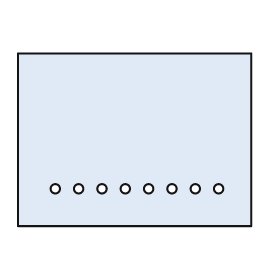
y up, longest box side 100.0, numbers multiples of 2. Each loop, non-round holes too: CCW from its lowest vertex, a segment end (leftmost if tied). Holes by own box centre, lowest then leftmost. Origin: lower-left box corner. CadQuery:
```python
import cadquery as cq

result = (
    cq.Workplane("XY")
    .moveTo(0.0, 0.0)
    .lineTo(100.0, 0.0)
    .lineTo(100.0, 74.0)
    .lineTo(0.0, 74.0)
    .close()
    .moveTo(16.0, 16.0)
    .circle(2.0)
    .moveTo(26.0, 16.0)
    .circle(2.0)
    .moveTo(36.0, 16.0)
    .circle(2.0)
    .moveTo(46.0, 16.0)
    .circle(2.0)
    .moveTo(56.0, 16.0)
    .circle(2.0)
    .moveTo(66.0, 16.0)
    .circle(2.0)
    .moveTo(76.0, 16.0)
    .circle(2.0)
    .moveTo(86.0, 16.0)
    .circle(2.0)
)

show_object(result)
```